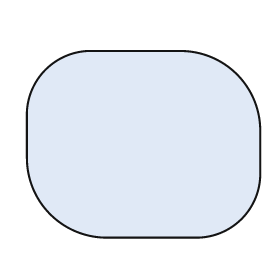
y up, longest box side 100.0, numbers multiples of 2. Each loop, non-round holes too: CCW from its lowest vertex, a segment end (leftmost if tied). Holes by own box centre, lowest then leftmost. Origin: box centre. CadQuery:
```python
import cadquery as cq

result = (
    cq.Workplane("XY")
    .moveTo(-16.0, -40.0)
    .lineTo(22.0, -40.0)
    .threePointArc((42.0, -32.0), (50.0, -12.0))
    .lineTo(50.0, 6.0)
    .threePointArc((40.0, 30.0), (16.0, 40.0))
    .lineTo(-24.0, 40.0)
    .threePointArc((-42.0, 32.0), (-50.0, 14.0))
    .lineTo(-50.0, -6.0)
    .threePointArc((-40.0, -30.0), (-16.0, -40.0))
    .close()
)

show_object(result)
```